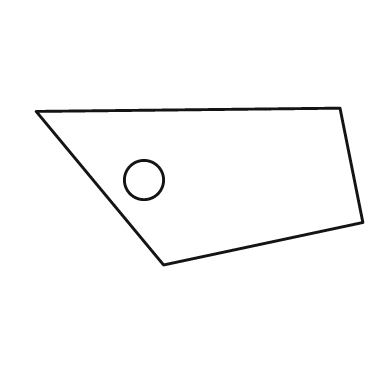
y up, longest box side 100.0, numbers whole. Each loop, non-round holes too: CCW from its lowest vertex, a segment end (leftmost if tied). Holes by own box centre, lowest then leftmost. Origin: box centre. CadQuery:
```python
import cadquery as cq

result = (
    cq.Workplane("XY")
    .moveTo(-11.0, -24.0)
    .lineTo(50.0, -11.0)
    .lineTo(43.0, 24.0)
    .lineTo(-50.0, 23.0)
    .close()
    .moveTo(-17.0, 2.0)
    .circle(6.0)
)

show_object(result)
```